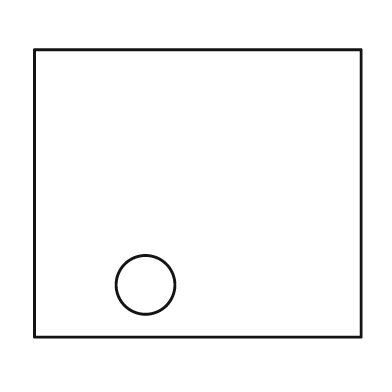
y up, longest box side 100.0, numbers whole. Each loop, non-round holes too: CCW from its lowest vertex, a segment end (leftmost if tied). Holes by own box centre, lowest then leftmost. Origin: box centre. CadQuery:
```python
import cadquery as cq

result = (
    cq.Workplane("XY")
    .moveTo(-50.0, -44.0)
    .lineTo(50.0, -44.0)
    .lineTo(50.0, 44.0)
    .lineTo(-50.0, 44.0)
    .close()
    .moveTo(-16.0, -28.0)
    .circle(9.0)
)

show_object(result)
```